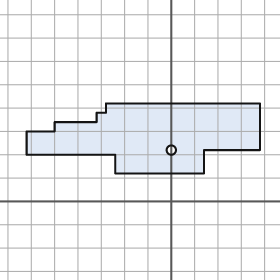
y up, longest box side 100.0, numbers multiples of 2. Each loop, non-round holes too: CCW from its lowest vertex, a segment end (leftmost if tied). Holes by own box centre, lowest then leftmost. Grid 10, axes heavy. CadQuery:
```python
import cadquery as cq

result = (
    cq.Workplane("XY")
    .moveTo(-24.0, 12.0)
    .lineTo(14.0, 12.0)
    .lineTo(14.0, 22.0)
    .lineTo(38.0, 22.0)
    .lineTo(38.0, 42.0)
    .lineTo(-28.0, 42.0)
    .lineTo(-28.0, 38.0)
    .lineTo(-32.0, 38.0)
    .lineTo(-32.0, 34.0)
    .lineTo(-50.0, 34.0)
    .lineTo(-50.0, 30.0)
    .lineTo(-62.0, 30.0)
    .lineTo(-62.0, 20.0)
    .lineTo(-24.0, 20.0)
    .close()
    .moveTo(0.0, 22.0)
    .circle(2.0)
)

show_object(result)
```